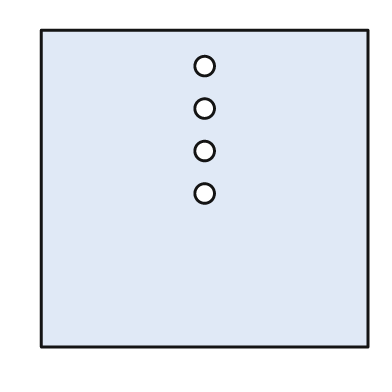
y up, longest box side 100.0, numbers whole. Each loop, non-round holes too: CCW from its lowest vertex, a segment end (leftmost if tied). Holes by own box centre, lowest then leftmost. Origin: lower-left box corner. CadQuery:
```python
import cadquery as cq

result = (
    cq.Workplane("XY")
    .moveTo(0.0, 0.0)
    .lineTo(100.0, 0.0)
    .lineTo(100.0, 97.0)
    .lineTo(0.0, 97.0)
    .close()
    .moveTo(50.0, 47.0)
    .circle(3.0)
    .moveTo(50.0, 60.0)
    .circle(3.0)
    .moveTo(50.0, 73.0)
    .circle(3.0)
    .moveTo(50.0, 86.0)
    .circle(3.0)
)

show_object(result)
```